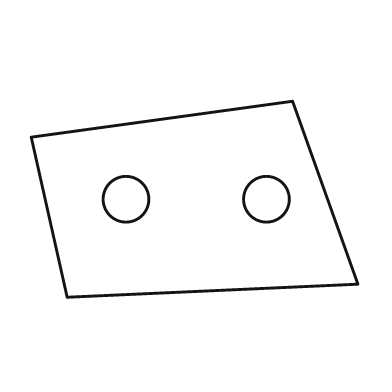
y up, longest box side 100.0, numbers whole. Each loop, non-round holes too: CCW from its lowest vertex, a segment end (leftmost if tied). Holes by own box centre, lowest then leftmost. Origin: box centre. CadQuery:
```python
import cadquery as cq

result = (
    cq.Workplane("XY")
    .moveTo(-39.0, -30.0)
    .lineTo(50.0, -26.0)
    .lineTo(30.0, 30.0)
    .lineTo(-50.0, 19.0)
    .close()
    .moveTo(-21.0, 0.0)
    .circle(7.0)
    .moveTo(22.0, 0.0)
    .circle(7.0)
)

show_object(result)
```